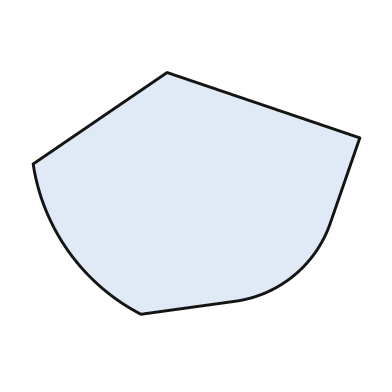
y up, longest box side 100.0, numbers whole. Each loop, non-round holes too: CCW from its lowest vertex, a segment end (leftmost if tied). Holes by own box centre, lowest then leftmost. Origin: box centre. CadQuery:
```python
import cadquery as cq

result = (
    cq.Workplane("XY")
    .moveTo(-17.0, -37.0)
    .lineTo(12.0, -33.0)
    .threePointArc((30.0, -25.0), (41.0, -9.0))
    .lineTo(50.0, 17.0)
    .lineTo(-9.0, 37.0)
    .lineTo(-50.0, 9.0)
    .threePointArc((-39.0, -18.0), (-17.0, -37.0))
    .close()
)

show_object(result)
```